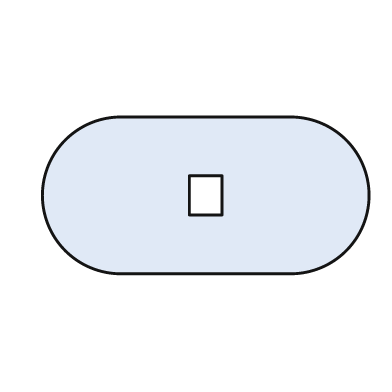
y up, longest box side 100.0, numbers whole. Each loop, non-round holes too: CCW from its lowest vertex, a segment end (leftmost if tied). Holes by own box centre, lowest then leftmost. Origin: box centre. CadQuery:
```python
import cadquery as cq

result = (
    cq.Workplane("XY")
    .moveTo(-26.0, -24.0)
    .lineTo(26.0, -24.0)
    .threePointArc((50.0, 0.0), (26.0, 24.0))
    .lineTo(-26.0, 24.0)
    .threePointArc((-50.0, 0.0), (-26.0, -24.0))
    .close()
    .moveTo(-5.0, -6.0)
    .lineTo(5.0, -6.0)
    .lineTo(5.0, 6.0)
    .lineTo(-5.0, 6.0)
    .close()
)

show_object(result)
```